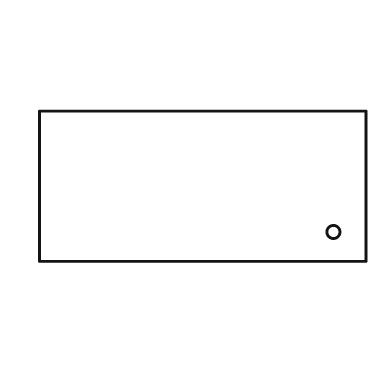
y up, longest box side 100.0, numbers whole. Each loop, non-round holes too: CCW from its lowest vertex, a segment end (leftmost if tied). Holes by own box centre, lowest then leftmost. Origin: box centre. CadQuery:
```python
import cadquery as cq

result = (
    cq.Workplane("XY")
    .moveTo(-50.0, -23.0)
    .lineTo(50.0, -23.0)
    .lineTo(50.0, 23.0)
    .lineTo(-50.0, 23.0)
    .close()
    .moveTo(40.0, -14.0)
    .circle(2.0)
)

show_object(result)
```